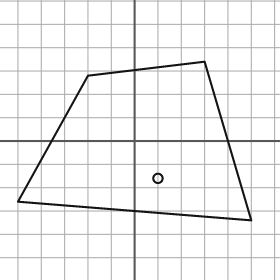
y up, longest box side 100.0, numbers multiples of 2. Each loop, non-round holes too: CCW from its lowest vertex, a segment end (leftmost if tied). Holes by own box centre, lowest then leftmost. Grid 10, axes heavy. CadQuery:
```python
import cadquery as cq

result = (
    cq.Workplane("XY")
    .moveTo(50.0, -34.0)
    .lineTo(30.0, 34.0)
    .lineTo(-20.0, 28.0)
    .lineTo(-50.0, -26.0)
    .close()
    .moveTo(10.0, -16.0)
    .circle(2.0)
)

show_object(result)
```